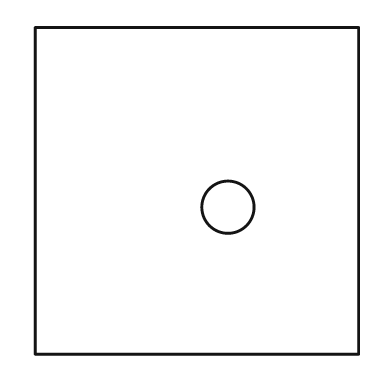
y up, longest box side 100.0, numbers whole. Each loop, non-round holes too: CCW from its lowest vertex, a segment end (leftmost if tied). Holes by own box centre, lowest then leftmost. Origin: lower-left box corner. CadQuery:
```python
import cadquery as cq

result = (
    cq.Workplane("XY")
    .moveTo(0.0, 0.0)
    .lineTo(99.0, 0.0)
    .lineTo(99.0, 100.0)
    .lineTo(0.0, 100.0)
    .close()
    .moveTo(59.0, 45.0)
    .circle(8.0)
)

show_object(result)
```